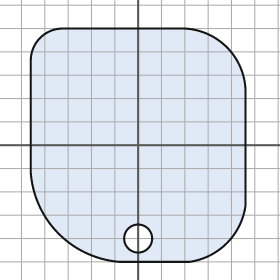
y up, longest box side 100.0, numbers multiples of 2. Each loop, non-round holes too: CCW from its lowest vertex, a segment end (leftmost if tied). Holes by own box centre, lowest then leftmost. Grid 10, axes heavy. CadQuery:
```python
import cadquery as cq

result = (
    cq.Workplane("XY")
    .moveTo(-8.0, -50.0)
    .lineTo(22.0, -50.0)
    .threePointArc((38.0, -42.0), (46.0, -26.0))
    .lineTo(46.0, 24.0)
    .threePointArc((38.0, 42.0), (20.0, 50.0))
    .lineTo(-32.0, 50.0)
    .threePointArc((-42.0, 46.0), (-46.0, 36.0))
    .lineTo(-46.0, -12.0)
    .threePointArc((-34.0, -38.0), (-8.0, -50.0))
    .close()
    .moveTo(0.0, -40.0)
    .circle(6.0)
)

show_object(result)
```